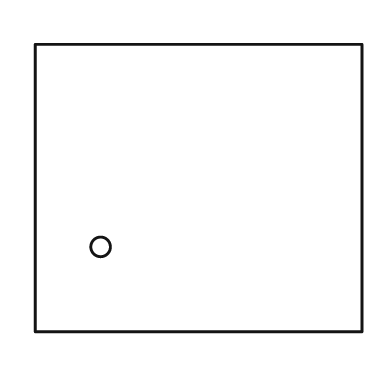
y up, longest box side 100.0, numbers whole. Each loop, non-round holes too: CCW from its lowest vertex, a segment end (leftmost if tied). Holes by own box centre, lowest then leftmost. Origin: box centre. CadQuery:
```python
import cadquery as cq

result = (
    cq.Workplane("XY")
    .moveTo(-50.0, -44.0)
    .lineTo(50.0, -44.0)
    .lineTo(50.0, 44.0)
    .lineTo(-50.0, 44.0)
    .close()
    .moveTo(-30.0, -18.0)
    .circle(3.0)
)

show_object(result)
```